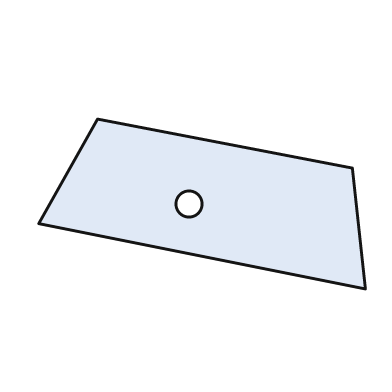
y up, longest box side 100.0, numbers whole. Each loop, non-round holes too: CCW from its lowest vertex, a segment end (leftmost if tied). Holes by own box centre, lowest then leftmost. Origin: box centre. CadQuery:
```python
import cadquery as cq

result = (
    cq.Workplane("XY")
    .moveTo(50.0, -26.0)
    .lineTo(46.0, 11.0)
    .lineTo(-32.0, 26.0)
    .lineTo(-50.0, -6.0)
    .close()
    .moveTo(-4.0, 0.0)
    .circle(4.0)
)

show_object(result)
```